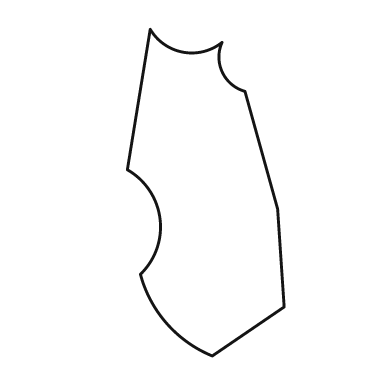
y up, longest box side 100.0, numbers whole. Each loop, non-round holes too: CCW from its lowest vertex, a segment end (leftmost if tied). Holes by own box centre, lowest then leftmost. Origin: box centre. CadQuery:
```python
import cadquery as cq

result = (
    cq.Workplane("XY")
    .moveTo(2.0, -50.0)
    .lineTo(24.0, -35.0)
    .lineTo(22.0, -5.0)
    .lineTo(12.0, 31.0)
    .threePointArc((5.0, 37.0), (5.0, 46.0))
    .threePointArc((-7.0, 43.0), (-17.0, 50.0))
    .lineTo(-24.0, 7.0)
    .threePointArc((-14.0, -8.0), (-20.0, -25.0))
    .threePointArc((-12.0, -40.0), (2.0, -50.0))
    .close()
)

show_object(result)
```